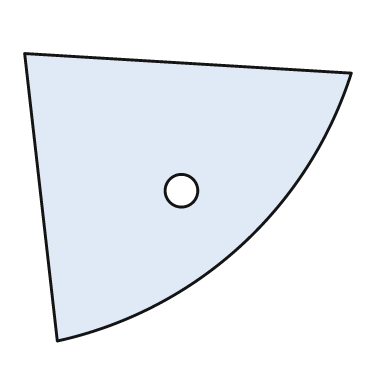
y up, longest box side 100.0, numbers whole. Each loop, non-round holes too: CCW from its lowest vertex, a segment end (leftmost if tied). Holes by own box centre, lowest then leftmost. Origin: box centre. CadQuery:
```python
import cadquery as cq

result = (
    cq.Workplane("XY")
    .moveTo(-40.0, -44.0)
    .threePointArc((16.0, -15.0), (50.0, 38.0))
    .lineTo(-50.0, 44.0)
    .close()
    .moveTo(-2.0, 2.0)
    .circle(5.0)
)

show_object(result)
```